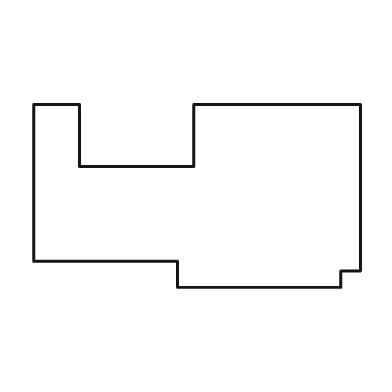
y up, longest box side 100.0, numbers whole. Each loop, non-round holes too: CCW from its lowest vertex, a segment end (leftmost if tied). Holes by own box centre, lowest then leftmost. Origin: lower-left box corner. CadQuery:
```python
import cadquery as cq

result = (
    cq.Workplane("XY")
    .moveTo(44.0, 0.0)
    .lineTo(94.0, 0.0)
    .lineTo(94.0, 5.0)
    .lineTo(100.0, 5.0)
    .lineTo(100.0, 56.0)
    .lineTo(49.0, 56.0)
    .lineTo(49.0, 37.0)
    .lineTo(14.0, 37.0)
    .lineTo(14.0, 56.0)
    .lineTo(0.0, 56.0)
    .lineTo(0.0, 8.0)
    .lineTo(44.0, 8.0)
    .close()
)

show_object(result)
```